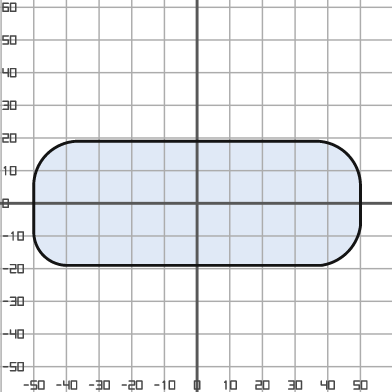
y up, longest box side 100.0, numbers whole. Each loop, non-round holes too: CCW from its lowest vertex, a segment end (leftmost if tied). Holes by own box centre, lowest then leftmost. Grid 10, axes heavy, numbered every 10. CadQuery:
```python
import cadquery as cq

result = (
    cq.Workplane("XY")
    .moveTo(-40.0, -19.0)
    .lineTo(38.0, -19.0)
    .threePointArc((46.0, -15.0), (50.0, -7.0))
    .lineTo(50.0, 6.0)
    .threePointArc((46.0, 15.0), (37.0, 19.0))
    .lineTo(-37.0, 19.0)
    .threePointArc((-46.0, 15.0), (-50.0, 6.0))
    .lineTo(-50.0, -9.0)
    .threePointArc((-47.0, -16.0), (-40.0, -19.0))
    .close()
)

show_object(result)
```